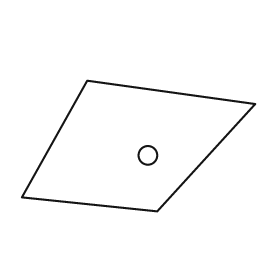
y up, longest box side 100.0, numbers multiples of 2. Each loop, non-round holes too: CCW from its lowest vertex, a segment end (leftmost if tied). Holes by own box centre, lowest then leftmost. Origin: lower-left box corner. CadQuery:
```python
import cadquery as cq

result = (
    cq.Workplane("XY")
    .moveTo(58.0, 0.0)
    .lineTo(100.0, 46.0)
    .lineTo(28.0, 56.0)
    .lineTo(0.0, 6.0)
    .close()
    .moveTo(54.0, 24.0)
    .circle(4.0)
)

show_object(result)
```